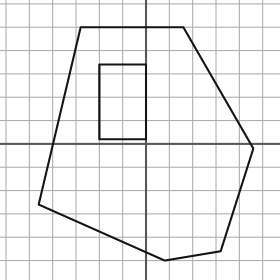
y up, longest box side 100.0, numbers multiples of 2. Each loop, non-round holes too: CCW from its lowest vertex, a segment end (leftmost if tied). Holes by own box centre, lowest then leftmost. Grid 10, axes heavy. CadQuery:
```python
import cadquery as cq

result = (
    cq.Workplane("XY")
    .moveTo(8.0, -50.0)
    .lineTo(32.0, -46.0)
    .lineTo(46.0, -2.0)
    .lineTo(16.0, 50.0)
    .lineTo(-28.0, 50.0)
    .lineTo(-46.0, -26.0)
    .close()
    .moveTo(-20.0, 2.0)
    .lineTo(0.0, 2.0)
    .lineTo(0.0, 34.0)
    .lineTo(-20.0, 34.0)
    .close()
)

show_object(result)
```